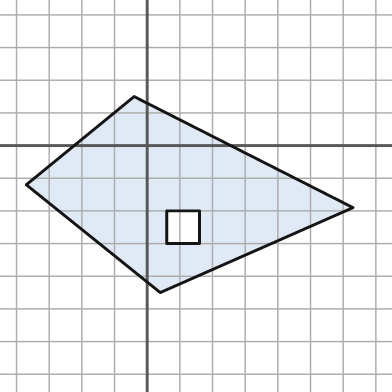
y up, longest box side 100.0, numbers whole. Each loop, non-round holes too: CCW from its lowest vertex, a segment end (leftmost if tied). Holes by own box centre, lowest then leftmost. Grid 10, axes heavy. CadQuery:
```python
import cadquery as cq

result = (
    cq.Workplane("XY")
    .moveTo(4.0, -45.0)
    .lineTo(63.0, -19.0)
    .lineTo(-4.0, 15.0)
    .lineTo(-37.0, -12.0)
    .close()
    .moveTo(6.0, -30.0)
    .lineTo(16.0, -30.0)
    .lineTo(16.0, -20.0)
    .lineTo(6.0, -20.0)
    .close()
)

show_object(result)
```